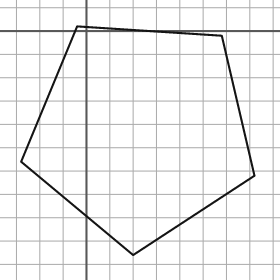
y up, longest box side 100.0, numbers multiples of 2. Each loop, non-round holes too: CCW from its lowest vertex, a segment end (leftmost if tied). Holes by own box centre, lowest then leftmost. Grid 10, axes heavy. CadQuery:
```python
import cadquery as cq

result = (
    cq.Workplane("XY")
    .moveTo(20.0, -96.0)
    .lineTo(72.0, -62.0)
    .lineTo(58.0, -2.0)
    .lineTo(-4.0, 2.0)
    .lineTo(-28.0, -56.0)
    .close()
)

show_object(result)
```